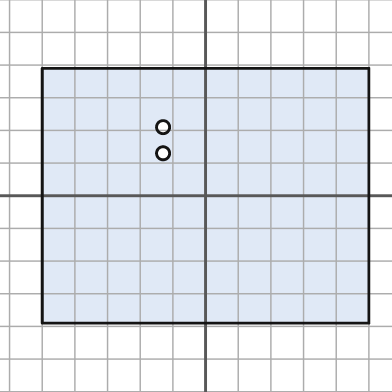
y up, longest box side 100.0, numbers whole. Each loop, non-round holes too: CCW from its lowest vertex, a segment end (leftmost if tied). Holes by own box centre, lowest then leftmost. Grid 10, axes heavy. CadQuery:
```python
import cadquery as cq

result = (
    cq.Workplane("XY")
    .moveTo(-50.0, -39.0)
    .lineTo(50.0, -39.0)
    .lineTo(50.0, 39.0)
    .lineTo(-50.0, 39.0)
    .close()
    .moveTo(-13.0, 13.0)
    .circle(2.0)
    .moveTo(-13.0, 21.0)
    .circle(2.0)
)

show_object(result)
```